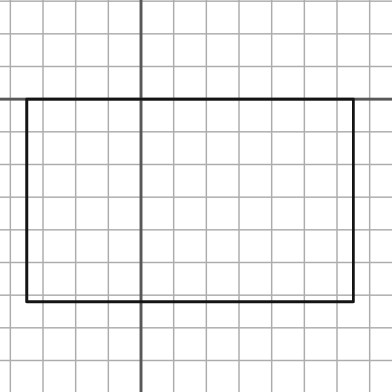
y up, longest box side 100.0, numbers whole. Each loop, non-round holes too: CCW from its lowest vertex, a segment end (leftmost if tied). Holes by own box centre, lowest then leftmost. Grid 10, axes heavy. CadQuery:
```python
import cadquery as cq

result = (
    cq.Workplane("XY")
    .moveTo(-35.0, -62.0)
    .lineTo(65.0, -62.0)
    .lineTo(65.0, 0.0)
    .lineTo(-35.0, 0.0)
    .close()
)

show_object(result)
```